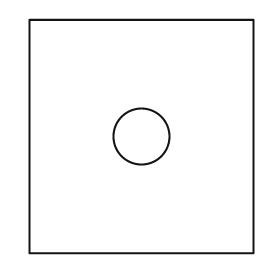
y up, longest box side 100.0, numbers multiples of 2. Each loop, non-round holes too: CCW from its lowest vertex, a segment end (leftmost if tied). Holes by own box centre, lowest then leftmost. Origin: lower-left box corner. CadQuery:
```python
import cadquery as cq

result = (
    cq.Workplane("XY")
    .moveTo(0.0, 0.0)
    .lineTo(96.0, 0.0)
    .lineTo(96.0, 100.0)
    .lineTo(0.0, 100.0)
    .close()
    .moveTo(48.0, 50.0)
    .circle(12.0)
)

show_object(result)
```